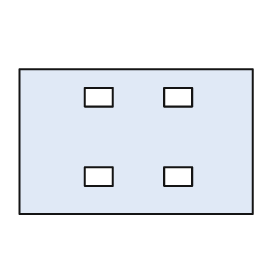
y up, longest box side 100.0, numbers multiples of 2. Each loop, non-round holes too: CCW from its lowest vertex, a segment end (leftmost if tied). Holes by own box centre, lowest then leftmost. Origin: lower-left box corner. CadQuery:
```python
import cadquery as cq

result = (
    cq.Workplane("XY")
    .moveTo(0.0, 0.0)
    .lineTo(100.0, 0.0)
    .lineTo(100.0, 62.0)
    .lineTo(0.0, 62.0)
    .close()
    .moveTo(28.0, 12.0)
    .lineTo(40.0, 12.0)
    .lineTo(40.0, 20.0)
    .lineTo(28.0, 20.0)
    .close()
    .moveTo(62.0, 12.0)
    .lineTo(74.0, 12.0)
    .lineTo(74.0, 20.0)
    .lineTo(62.0, 20.0)
    .close()
    .moveTo(28.0, 46.0)
    .lineTo(40.0, 46.0)
    .lineTo(40.0, 54.0)
    .lineTo(28.0, 54.0)
    .close()
    .moveTo(62.0, 46.0)
    .lineTo(74.0, 46.0)
    .lineTo(74.0, 54.0)
    .lineTo(62.0, 54.0)
    .close()
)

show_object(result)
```